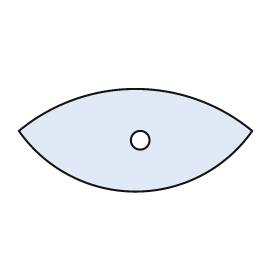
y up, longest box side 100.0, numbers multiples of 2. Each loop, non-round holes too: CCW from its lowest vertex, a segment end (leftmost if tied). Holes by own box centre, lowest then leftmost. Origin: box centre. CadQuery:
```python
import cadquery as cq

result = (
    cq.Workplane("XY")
    .moveTo(-50.0, 4.0)
    .threePointArc((0.0, -22.0), (50.0, 4.0))
    .threePointArc((0.0, 22.0), (-50.0, 4.0))
    .close()
    .moveTo(2.0, 0.0)
    .circle(4.0)
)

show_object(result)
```